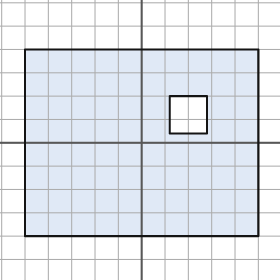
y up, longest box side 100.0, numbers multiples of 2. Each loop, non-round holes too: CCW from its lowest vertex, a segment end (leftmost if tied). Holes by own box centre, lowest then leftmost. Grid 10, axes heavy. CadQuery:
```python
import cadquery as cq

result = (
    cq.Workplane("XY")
    .moveTo(-50.0, -40.0)
    .lineTo(50.0, -40.0)
    .lineTo(50.0, 40.0)
    .lineTo(-50.0, 40.0)
    .close()
    .moveTo(12.0, 4.0)
    .lineTo(28.0, 4.0)
    .lineTo(28.0, 20.0)
    .lineTo(12.0, 20.0)
    .close()
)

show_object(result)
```